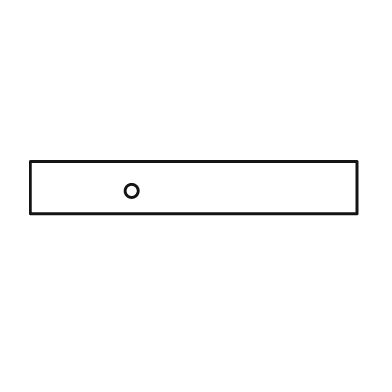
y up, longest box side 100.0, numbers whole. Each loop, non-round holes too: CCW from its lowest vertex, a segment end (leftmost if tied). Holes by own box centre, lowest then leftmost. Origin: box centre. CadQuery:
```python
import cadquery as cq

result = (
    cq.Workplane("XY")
    .moveTo(-50.0, -8.0)
    .lineTo(50.0, -8.0)
    .lineTo(50.0, 8.0)
    .lineTo(-50.0, 8.0)
    .close()
    .moveTo(-19.0, -1.0)
    .circle(2.0)
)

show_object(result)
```